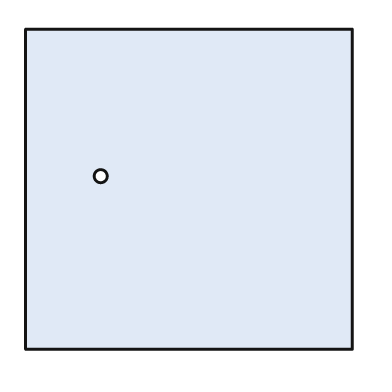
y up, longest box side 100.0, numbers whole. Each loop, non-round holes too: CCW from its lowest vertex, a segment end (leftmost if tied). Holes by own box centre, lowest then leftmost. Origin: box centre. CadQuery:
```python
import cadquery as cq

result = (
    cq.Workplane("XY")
    .moveTo(-50.0, -49.0)
    .lineTo(50.0, -49.0)
    .lineTo(50.0, 49.0)
    .lineTo(-50.0, 49.0)
    .close()
    .moveTo(-27.0, 4.0)
    .circle(2.0)
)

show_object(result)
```